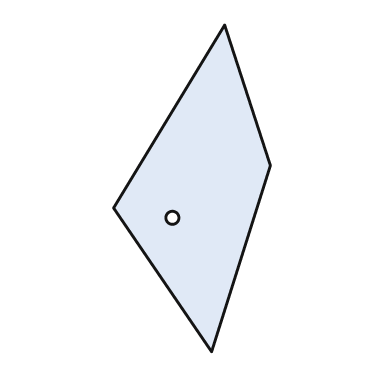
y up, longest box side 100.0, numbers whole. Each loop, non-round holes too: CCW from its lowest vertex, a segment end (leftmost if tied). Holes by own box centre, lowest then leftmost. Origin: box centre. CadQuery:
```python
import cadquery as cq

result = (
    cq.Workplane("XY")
    .moveTo(6.0, -50.0)
    .lineTo(24.0, 7.0)
    .lineTo(10.0, 50.0)
    .lineTo(-24.0, -6.0)
    .close()
    .moveTo(-6.0, -9.0)
    .circle(2.0)
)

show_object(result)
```